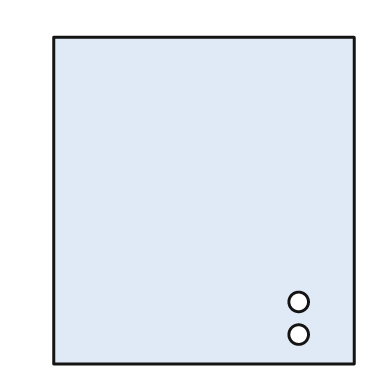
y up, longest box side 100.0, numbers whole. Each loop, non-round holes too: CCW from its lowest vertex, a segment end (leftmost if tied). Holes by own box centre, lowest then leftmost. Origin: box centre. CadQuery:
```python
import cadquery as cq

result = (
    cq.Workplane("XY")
    .moveTo(-46.0, -50.0)
    .lineTo(46.0, -50.0)
    .lineTo(46.0, 50.0)
    .lineTo(-46.0, 50.0)
    .close()
    .moveTo(29.0, -41.0)
    .circle(3.0)
    .moveTo(29.0, -31.0)
    .circle(3.0)
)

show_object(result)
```